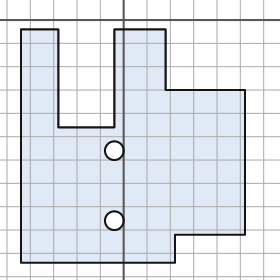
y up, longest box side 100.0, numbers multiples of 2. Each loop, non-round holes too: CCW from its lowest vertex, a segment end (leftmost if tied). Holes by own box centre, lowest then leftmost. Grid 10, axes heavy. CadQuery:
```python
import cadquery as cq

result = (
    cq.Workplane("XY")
    .moveTo(-44.0, -104.0)
    .lineTo(22.0, -104.0)
    .lineTo(22.0, -92.0)
    .lineTo(52.0, -92.0)
    .lineTo(52.0, -30.0)
    .lineTo(18.0, -30.0)
    .lineTo(18.0, -4.0)
    .lineTo(-4.0, -4.0)
    .lineTo(-4.0, -46.0)
    .lineTo(-28.0, -46.0)
    .lineTo(-28.0, -4.0)
    .lineTo(-44.0, -4.0)
    .close()
    .moveTo(-4.0, -86.0)
    .circle(4.0)
    .moveTo(-4.0, -56.0)
    .circle(4.0)
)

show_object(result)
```